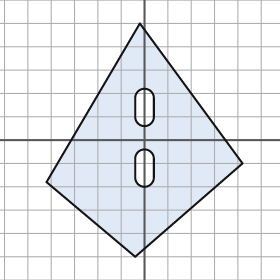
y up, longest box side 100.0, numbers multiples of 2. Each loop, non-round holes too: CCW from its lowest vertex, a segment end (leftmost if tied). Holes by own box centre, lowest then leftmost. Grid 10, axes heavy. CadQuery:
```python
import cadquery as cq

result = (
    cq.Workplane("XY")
    .moveTo(-4.0, -50.0)
    .lineTo(42.0, -10.0)
    .lineTo(-2.0, 50.0)
    .lineTo(-42.0, -18.0)
    .close()
    .moveTo(-4.0, -16.0)
    .threePointArc((0.0, -20.0), (4.0, -16.0))
    .lineTo(4.0, -8.0)
    .threePointArc((0.0, -4.0), (-4.0, -8.0))
    .close()
    .moveTo(-4.0, 10.0)
    .threePointArc((0.0, 6.0), (4.0, 10.0))
    .lineTo(4.0, 18.0)
    .threePointArc((0.0, 22.0), (-4.0, 18.0))
    .close()
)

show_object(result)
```